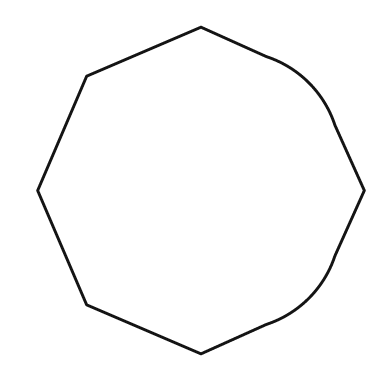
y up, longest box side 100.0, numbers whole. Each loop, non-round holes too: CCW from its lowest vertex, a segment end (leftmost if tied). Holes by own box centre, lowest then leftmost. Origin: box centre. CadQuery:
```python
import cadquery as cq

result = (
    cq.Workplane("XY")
    .moveTo(0.0, -50.0)
    .lineTo(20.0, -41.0)
    .threePointArc((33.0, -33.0), (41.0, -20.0))
    .lineTo(50.0, 0.0)
    .lineTo(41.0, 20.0)
    .threePointArc((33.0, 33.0), (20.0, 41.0))
    .lineTo(0.0, 50.0)
    .lineTo(-35.0, 35.0)
    .lineTo(-50.0, 0.0)
    .lineTo(-35.0, -35.0)
    .close()
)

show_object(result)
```